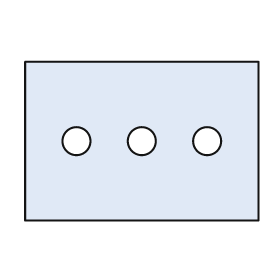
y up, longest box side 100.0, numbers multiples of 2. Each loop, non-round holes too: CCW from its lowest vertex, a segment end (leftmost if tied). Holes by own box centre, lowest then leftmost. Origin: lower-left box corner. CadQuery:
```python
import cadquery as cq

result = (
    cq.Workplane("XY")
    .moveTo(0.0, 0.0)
    .lineTo(100.0, 0.0)
    .lineTo(100.0, 68.0)
    .lineTo(0.0, 68.0)
    .close()
    .moveTo(22.0, 34.0)
    .circle(6.0)
    .moveTo(50.0, 34.0)
    .circle(6.0)
    .moveTo(78.0, 34.0)
    .circle(6.0)
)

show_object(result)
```